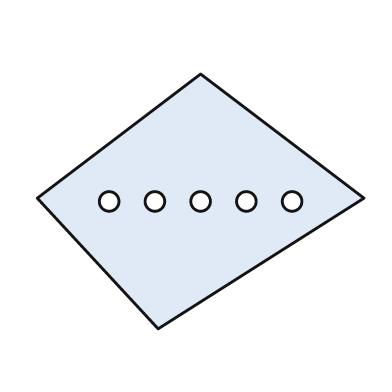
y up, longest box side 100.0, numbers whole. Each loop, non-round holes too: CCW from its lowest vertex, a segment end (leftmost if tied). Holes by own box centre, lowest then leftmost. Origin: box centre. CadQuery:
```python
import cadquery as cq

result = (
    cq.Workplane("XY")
    .moveTo(-13.0, -39.0)
    .lineTo(50.0, 1.0)
    .lineTo(0.0, 39.0)
    .lineTo(-50.0, 1.0)
    .close()
    .moveTo(-28.0, 0.0)
    .circle(3.0)
    .moveTo(-14.0, 0.0)
    .circle(3.0)
    .moveTo(0.0, 0.0)
    .circle(3.0)
    .moveTo(14.0, 0.0)
    .circle(3.0)
    .moveTo(28.0, 0.0)
    .circle(3.0)
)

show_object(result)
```